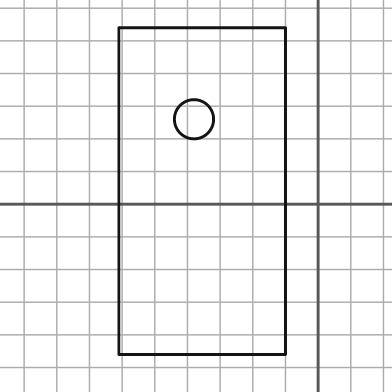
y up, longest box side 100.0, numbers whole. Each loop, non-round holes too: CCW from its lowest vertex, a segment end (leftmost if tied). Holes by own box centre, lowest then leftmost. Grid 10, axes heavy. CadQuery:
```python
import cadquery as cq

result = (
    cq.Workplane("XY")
    .moveTo(-61.0, -46.0)
    .lineTo(-10.0, -46.0)
    .lineTo(-10.0, 54.0)
    .lineTo(-61.0, 54.0)
    .close()
    .moveTo(-38.0, 26.0)
    .circle(6.0)
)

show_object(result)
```